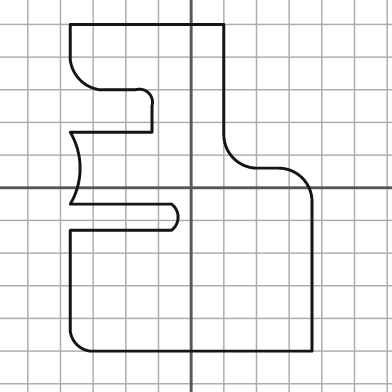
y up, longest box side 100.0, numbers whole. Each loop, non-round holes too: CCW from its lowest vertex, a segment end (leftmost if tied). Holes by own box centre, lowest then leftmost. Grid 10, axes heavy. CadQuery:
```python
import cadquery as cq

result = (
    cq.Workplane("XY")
    .moveTo(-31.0, -50.0)
    .lineTo(37.0, -50.0)
    .lineTo(37.0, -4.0)
    .threePointArc((34.0, 3.0), (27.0, 6.0))
    .lineTo(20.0, 6.0)
    .threePointArc((13.0, 9.0), (10.0, 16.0))
    .lineTo(10.0, 50.0)
    .lineTo(-37.0, 50.0)
    .lineTo(-37.0, 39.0)
    .threePointArc((-34.0, 33.0), (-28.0, 30.0))
    .lineTo(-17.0, 30.0)
    .threePointArc((-13.0, 29.0), (-12.0, 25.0))
    .lineTo(-12.0, 17.0)
    .lineTo(-37.0, 17.0)
    .threePointArc((-34.0, 6.0), (-37.0, -5.0))
    .lineTo(-6.0, -5.0)
    .threePointArc((-4.0, -9.0), (-6.0, -13.0))
    .lineTo(-37.0, -13.0)
    .lineTo(-37.0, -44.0)
    .threePointArc((-35.0, -48.0), (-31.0, -50.0))
    .close()
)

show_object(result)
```